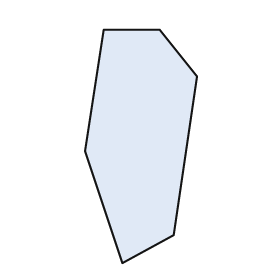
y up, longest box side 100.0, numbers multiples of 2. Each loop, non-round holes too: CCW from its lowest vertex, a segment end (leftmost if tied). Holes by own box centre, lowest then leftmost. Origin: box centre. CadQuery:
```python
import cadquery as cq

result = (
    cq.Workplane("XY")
    .moveTo(-8.0, -50.0)
    .lineTo(14.0, -38.0)
    .lineTo(24.0, 30.0)
    .lineTo(8.0, 50.0)
    .lineTo(-16.0, 50.0)
    .lineTo(-24.0, -2.0)
    .close()
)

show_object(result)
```